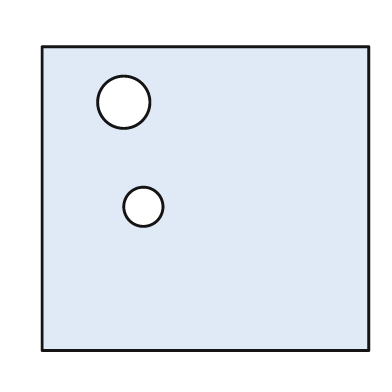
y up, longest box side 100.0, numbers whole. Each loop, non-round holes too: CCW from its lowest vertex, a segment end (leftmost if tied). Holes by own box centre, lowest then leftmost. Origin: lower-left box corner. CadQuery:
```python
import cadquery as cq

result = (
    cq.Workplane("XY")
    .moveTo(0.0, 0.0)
    .lineTo(100.0, 0.0)
    .lineTo(100.0, 93.0)
    .lineTo(0.0, 93.0)
    .close()
    .moveTo(31.0, 44.0)
    .circle(6.0)
    .moveTo(25.0, 76.0)
    .circle(8.0)
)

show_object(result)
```